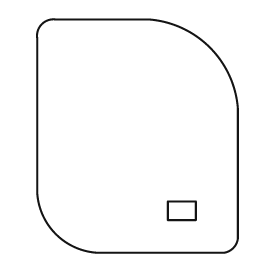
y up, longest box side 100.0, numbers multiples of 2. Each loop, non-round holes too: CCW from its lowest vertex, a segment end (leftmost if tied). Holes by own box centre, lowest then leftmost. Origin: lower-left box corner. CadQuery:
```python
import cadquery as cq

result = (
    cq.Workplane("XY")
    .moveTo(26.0, 0.0)
    .lineTo(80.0, 0.0)
    .threePointArc((84.0, 2.0), (86.0, 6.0))
    .lineTo(86.0, 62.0)
    .threePointArc((74.0, 88.0), (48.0, 100.0))
    .lineTo(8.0, 100.0)
    .threePointArc((2.0, 98.0), (0.0, 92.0))
    .lineTo(0.0, 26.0)
    .threePointArc((8.0, 8.0), (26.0, 0.0))
    .close()
    .moveTo(56.0, 14.0)
    .lineTo(68.0, 14.0)
    .lineTo(68.0, 22.0)
    .lineTo(56.0, 22.0)
    .close()
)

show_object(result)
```